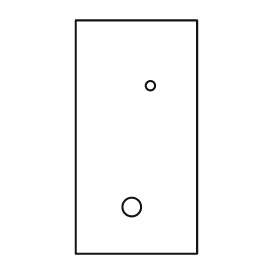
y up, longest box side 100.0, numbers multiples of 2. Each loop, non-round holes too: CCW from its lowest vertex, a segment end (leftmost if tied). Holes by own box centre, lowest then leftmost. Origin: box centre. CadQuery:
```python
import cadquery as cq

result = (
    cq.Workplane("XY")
    .moveTo(-26.0, -50.0)
    .lineTo(26.0, -50.0)
    .lineTo(26.0, 50.0)
    .lineTo(-26.0, 50.0)
    .close()
    .moveTo(-2.0, -30.0)
    .circle(4.0)
    .moveTo(6.0, 22.0)
    .circle(2.0)
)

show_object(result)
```